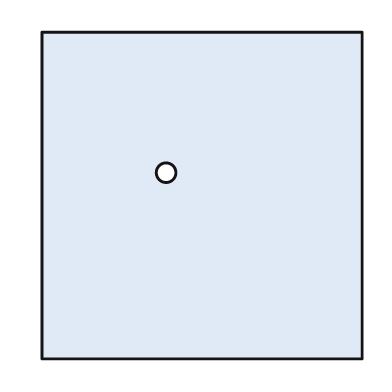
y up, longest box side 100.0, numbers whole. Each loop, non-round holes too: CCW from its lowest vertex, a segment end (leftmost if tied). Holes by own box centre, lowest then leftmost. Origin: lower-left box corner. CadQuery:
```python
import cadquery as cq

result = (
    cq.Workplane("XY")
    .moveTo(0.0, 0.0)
    .lineTo(98.0, 0.0)
    .lineTo(98.0, 100.0)
    .lineTo(0.0, 100.0)
    .close()
    .moveTo(38.0, 57.0)
    .circle(3.0)
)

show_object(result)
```